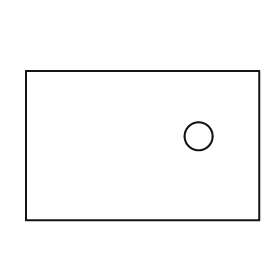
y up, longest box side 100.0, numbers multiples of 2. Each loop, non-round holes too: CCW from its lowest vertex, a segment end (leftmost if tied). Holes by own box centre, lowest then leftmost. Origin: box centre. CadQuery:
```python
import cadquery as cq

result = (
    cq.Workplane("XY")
    .moveTo(-50.0, -32.0)
    .lineTo(50.0, -32.0)
    .lineTo(50.0, 32.0)
    .lineTo(-50.0, 32.0)
    .close()
    .moveTo(24.0, 4.0)
    .circle(6.0)
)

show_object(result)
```